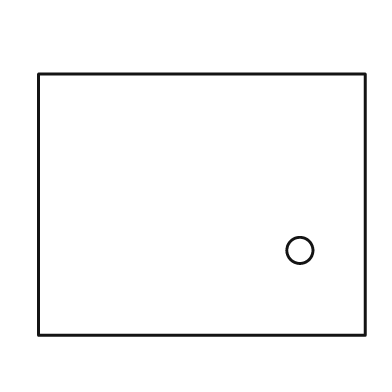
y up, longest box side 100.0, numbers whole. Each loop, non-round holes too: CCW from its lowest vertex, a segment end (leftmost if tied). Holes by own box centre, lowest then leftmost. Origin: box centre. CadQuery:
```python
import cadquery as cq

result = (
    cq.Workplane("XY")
    .moveTo(-50.0, -40.0)
    .lineTo(50.0, -40.0)
    .lineTo(50.0, 40.0)
    .lineTo(-50.0, 40.0)
    .close()
    .moveTo(30.0, -14.0)
    .circle(4.0)
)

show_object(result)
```